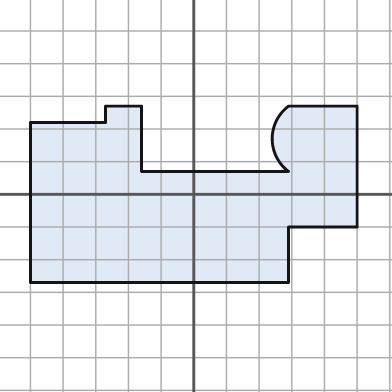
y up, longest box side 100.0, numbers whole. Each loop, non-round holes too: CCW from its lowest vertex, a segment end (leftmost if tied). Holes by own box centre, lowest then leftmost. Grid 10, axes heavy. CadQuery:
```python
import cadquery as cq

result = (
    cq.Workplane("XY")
    .moveTo(-50.0, -27.0)
    .lineTo(29.0, -27.0)
    .lineTo(29.0, -10.0)
    .lineTo(50.0, -10.0)
    .lineTo(50.0, 27.0)
    .lineTo(29.0, 27.0)
    .threePointArc((24.0, 17.0), (29.0, 7.0))
    .lineTo(-16.0, 7.0)
    .lineTo(-16.0, 27.0)
    .lineTo(-27.0, 27.0)
    .lineTo(-27.0, 22.0)
    .lineTo(-50.0, 22.0)
    .close()
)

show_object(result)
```